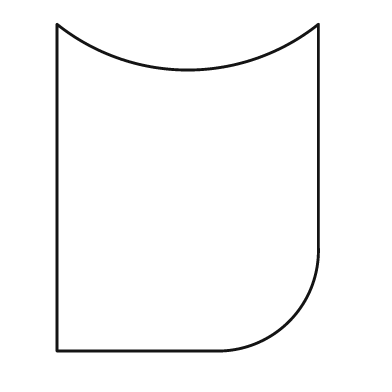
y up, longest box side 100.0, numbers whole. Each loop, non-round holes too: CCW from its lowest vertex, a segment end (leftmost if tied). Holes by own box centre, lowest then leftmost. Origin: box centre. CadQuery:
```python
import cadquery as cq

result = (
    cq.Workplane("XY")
    .moveTo(-40.0, -50.0)
    .lineTo(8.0, -50.0)
    .threePointArc((31.0, -41.0), (40.0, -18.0))
    .lineTo(40.0, 50.0)
    .threePointArc((0.0, 36.0), (-40.0, 50.0))
    .close()
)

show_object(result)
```